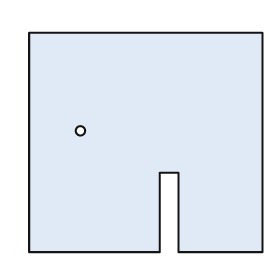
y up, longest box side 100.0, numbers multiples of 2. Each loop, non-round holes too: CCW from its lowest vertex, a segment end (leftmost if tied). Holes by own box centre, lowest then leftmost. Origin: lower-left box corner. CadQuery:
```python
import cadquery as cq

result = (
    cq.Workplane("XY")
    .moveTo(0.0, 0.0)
    .lineTo(56.0, 0.0)
    .lineTo(56.0, 34.0)
    .lineTo(64.0, 34.0)
    .lineTo(64.0, 0.0)
    .lineTo(100.0, 0.0)
    .lineTo(100.0, 94.0)
    .lineTo(0.0, 94.0)
    .close()
    .moveTo(22.0, 52.0)
    .circle(2.0)
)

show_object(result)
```